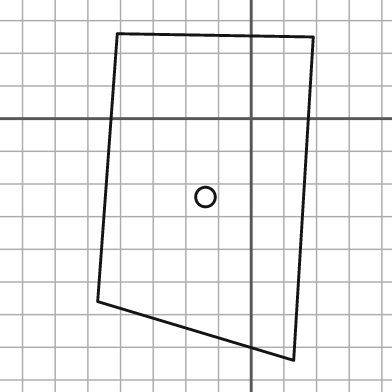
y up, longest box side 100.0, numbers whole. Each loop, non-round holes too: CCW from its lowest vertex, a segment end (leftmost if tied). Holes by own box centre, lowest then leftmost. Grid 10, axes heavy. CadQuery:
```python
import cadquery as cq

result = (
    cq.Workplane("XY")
    .moveTo(13.0, -74.0)
    .lineTo(19.0, 25.0)
    .lineTo(-41.0, 26.0)
    .lineTo(-47.0, -56.0)
    .close()
    .moveTo(-14.0, -24.0)
    .circle(3.0)
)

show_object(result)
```